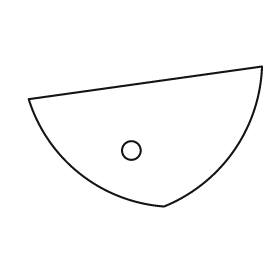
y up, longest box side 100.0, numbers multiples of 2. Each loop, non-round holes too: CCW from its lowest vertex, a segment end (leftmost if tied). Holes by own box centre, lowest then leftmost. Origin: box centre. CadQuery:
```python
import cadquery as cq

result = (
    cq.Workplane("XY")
    .moveTo(8.0, -30.0)
    .threePointArc((38.0, -6.0), (50.0, 30.0))
    .lineTo(-50.0, 16.0)
    .threePointArc((-28.0, -16.0), (8.0, -30.0))
    .close()
    .moveTo(-6.0, -6.0)
    .circle(4.0)
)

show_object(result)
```